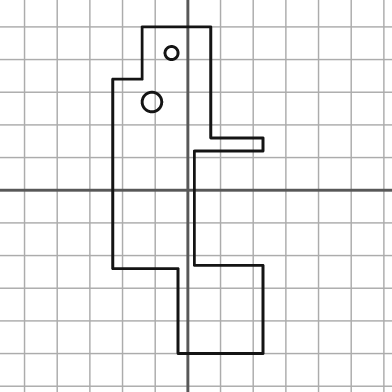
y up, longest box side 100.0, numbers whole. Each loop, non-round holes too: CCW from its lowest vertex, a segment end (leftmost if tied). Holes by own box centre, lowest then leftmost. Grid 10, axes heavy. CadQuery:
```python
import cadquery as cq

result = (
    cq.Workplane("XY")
    .moveTo(-3.0, -50.0)
    .lineTo(23.0, -50.0)
    .lineTo(23.0, -23.0)
    .lineTo(2.0, -23.0)
    .lineTo(2.0, 12.0)
    .lineTo(23.0, 12.0)
    .lineTo(23.0, 16.0)
    .lineTo(7.0, 16.0)
    .lineTo(7.0, 50.0)
    .lineTo(-14.0, 50.0)
    .lineTo(-14.0, 34.0)
    .lineTo(-23.0, 34.0)
    .lineTo(-23.0, -24.0)
    .lineTo(-3.0, -24.0)
    .close()
    .moveTo(-11.0, 27.0)
    .circle(3.0)
    .moveTo(-5.0, 42.0)
    .circle(2.0)
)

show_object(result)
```